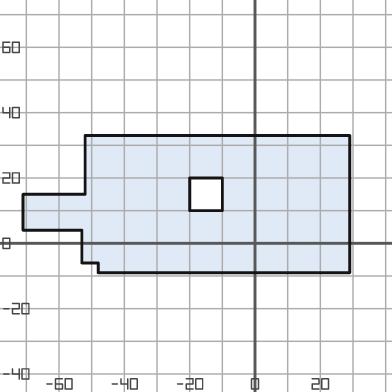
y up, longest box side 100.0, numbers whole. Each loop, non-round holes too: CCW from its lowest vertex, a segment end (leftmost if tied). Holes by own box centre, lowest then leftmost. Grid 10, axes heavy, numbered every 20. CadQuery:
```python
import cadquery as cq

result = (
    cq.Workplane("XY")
    .moveTo(-48.0, -9.0)
    .lineTo(29.0, -9.0)
    .lineTo(29.0, 33.0)
    .lineTo(-52.0, 33.0)
    .lineTo(-52.0, 15.0)
    .lineTo(-71.0, 15.0)
    .lineTo(-71.0, 4.0)
    .lineTo(-53.0, 4.0)
    .lineTo(-53.0, -6.0)
    .lineTo(-48.0, -6.0)
    .close()
    .moveTo(-20.0, 10.0)
    .lineTo(-10.0, 10.0)
    .lineTo(-10.0, 20.0)
    .lineTo(-20.0, 20.0)
    .close()
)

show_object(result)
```